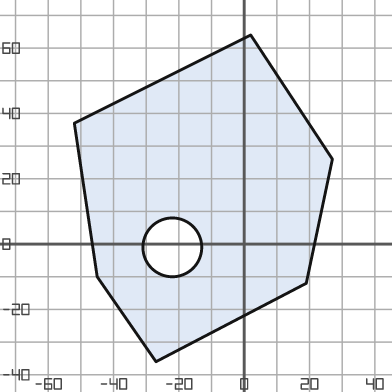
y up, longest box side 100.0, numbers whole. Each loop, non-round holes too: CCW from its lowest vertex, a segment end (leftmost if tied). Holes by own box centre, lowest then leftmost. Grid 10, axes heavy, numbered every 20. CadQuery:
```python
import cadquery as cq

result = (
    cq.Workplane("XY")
    .moveTo(-27.0, -36.0)
    .lineTo(19.0, -12.0)
    .lineTo(27.0, 26.0)
    .lineTo(2.0, 64.0)
    .lineTo(-52.0, 37.0)
    .lineTo(-45.0, -10.0)
    .close()
    .moveTo(-22.0, -1.0)
    .circle(9.0)
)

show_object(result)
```